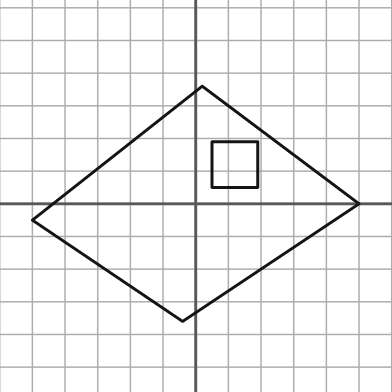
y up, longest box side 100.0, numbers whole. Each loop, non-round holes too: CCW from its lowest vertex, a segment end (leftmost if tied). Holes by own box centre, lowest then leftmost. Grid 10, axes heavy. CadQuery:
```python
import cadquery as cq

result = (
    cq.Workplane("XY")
    .moveTo(-4.0, -36.0)
    .lineTo(50.0, 0.0)
    .lineTo(2.0, 36.0)
    .lineTo(-50.0, -5.0)
    .close()
    .moveTo(5.0, 5.0)
    .lineTo(19.0, 5.0)
    .lineTo(19.0, 19.0)
    .lineTo(5.0, 19.0)
    .close()
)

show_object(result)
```